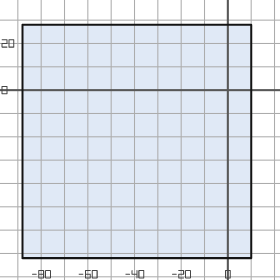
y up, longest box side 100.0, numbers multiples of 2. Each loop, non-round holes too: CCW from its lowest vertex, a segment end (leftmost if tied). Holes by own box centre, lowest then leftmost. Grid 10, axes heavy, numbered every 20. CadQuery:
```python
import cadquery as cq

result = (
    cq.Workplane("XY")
    .moveTo(-88.0, -72.0)
    .lineTo(10.0, -72.0)
    .lineTo(10.0, 28.0)
    .lineTo(-88.0, 28.0)
    .close()
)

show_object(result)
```